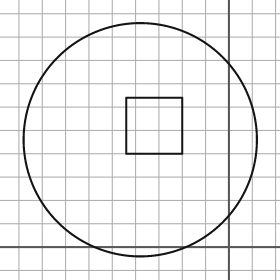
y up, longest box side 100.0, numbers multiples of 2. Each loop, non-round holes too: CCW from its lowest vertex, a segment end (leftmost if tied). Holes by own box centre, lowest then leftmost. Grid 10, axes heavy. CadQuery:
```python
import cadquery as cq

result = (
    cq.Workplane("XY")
    .moveTo(-38.0, 46.0)
    .circle(50.0)
    .moveTo(-44.0, 40.0)
    .lineTo(-20.0, 40.0)
    .lineTo(-20.0, 64.0)
    .lineTo(-44.0, 64.0)
    .close()
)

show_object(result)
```